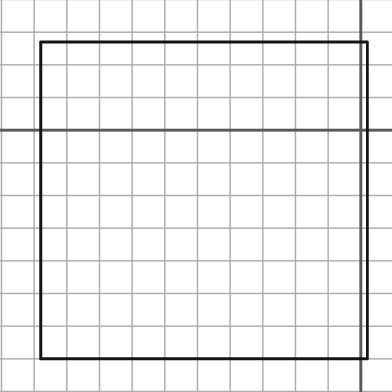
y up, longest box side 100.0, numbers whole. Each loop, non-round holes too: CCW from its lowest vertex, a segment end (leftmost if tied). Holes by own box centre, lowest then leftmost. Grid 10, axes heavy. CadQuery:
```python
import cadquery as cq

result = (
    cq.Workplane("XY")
    .moveTo(-98.0, -70.0)
    .lineTo(2.0, -70.0)
    .lineTo(2.0, 27.0)
    .lineTo(-98.0, 27.0)
    .close()
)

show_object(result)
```